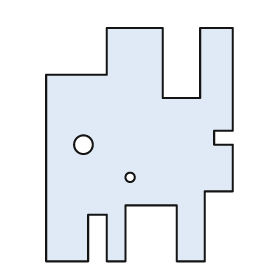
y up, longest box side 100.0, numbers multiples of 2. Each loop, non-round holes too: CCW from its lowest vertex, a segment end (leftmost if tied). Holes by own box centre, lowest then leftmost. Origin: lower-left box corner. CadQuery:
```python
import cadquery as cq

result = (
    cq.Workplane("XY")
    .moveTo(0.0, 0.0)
    .lineTo(18.0, 0.0)
    .lineTo(18.0, 20.0)
    .lineTo(26.0, 20.0)
    .lineTo(26.0, 0.0)
    .lineTo(34.0, 0.0)
    .lineTo(34.0, 24.0)
    .lineTo(56.0, 24.0)
    .lineTo(56.0, 0.0)
    .lineTo(68.0, 0.0)
    .lineTo(68.0, 30.0)
    .lineTo(80.0, 30.0)
    .lineTo(80.0, 50.0)
    .lineTo(72.0, 50.0)
    .lineTo(72.0, 56.0)
    .lineTo(80.0, 56.0)
    .lineTo(80.0, 100.0)
    .lineTo(66.0, 100.0)
    .lineTo(66.0, 70.0)
    .lineTo(50.0, 70.0)
    .lineTo(50.0, 100.0)
    .lineTo(26.0, 100.0)
    .lineTo(26.0, 80.0)
    .lineTo(0.0, 80.0)
    .close()
    .moveTo(36.0, 36.0)
    .circle(2.0)
    .moveTo(16.0, 50.0)
    .circle(4.0)
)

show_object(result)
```